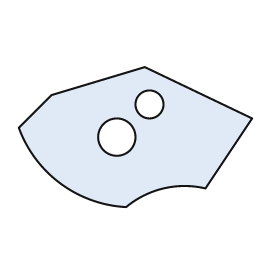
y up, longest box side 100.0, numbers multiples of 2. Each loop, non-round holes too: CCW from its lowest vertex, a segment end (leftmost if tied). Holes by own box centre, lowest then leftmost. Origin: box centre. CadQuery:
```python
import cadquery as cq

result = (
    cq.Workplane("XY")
    .moveTo(-4.0, -30.0)
    .threePointArc((12.0, -22.0), (30.0, -22.0))
    .lineTo(50.0, 8.0)
    .lineTo(4.0, 30.0)
    .lineTo(-36.0, 18.0)
    .lineTo(-50.0, 4.0)
    .threePointArc((-32.0, -20.0), (-4.0, -30.0))
    .close()
    .moveTo(-8.0, 0.0)
    .circle(8.0)
    .moveTo(6.0, 14.0)
    .circle(6.0)
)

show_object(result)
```